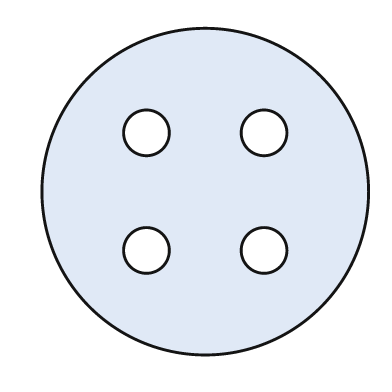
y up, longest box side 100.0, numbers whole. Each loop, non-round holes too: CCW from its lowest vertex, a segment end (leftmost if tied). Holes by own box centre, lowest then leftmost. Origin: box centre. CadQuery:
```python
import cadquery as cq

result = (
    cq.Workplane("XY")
    .moveTo(0.0, 0.0)
    .circle(50.0)
    .moveTo(-18.0, -18.0)
    .circle(7.0)
    .moveTo(18.0, -18.0)
    .circle(7.0)
    .moveTo(-18.0, 18.0)
    .circle(7.0)
    .moveTo(18.0, 18.0)
    .circle(7.0)
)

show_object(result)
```